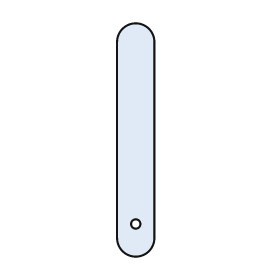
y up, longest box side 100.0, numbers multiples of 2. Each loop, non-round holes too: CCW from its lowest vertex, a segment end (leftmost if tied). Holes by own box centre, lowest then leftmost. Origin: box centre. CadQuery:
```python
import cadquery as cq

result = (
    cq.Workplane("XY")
    .moveTo(-8.0, -42.0)
    .threePointArc((0.0, -50.0), (8.0, -42.0))
    .lineTo(8.0, 42.0)
    .threePointArc((0.0, 50.0), (-8.0, 42.0))
    .close()
    .moveTo(0.0, -36.0)
    .circle(2.0)
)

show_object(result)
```